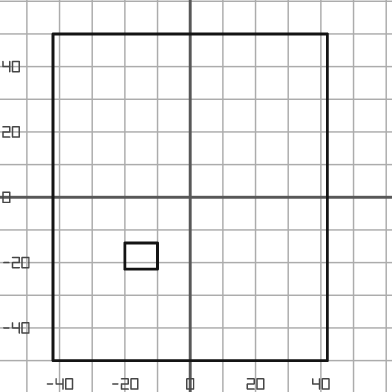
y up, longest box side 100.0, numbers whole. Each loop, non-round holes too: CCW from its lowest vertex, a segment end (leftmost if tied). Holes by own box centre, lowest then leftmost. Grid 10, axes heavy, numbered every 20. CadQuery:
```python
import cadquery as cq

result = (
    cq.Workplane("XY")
    .moveTo(-42.0, -50.0)
    .lineTo(42.0, -50.0)
    .lineTo(42.0, 50.0)
    .lineTo(-42.0, 50.0)
    .close()
    .moveTo(-20.0, -22.0)
    .lineTo(-10.0, -22.0)
    .lineTo(-10.0, -14.0)
    .lineTo(-20.0, -14.0)
    .close()
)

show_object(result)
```